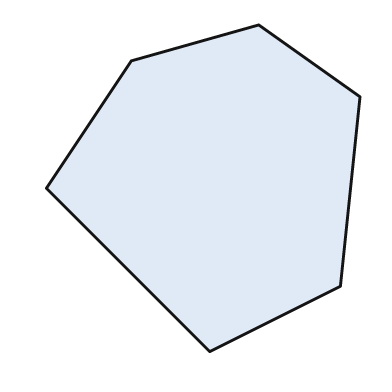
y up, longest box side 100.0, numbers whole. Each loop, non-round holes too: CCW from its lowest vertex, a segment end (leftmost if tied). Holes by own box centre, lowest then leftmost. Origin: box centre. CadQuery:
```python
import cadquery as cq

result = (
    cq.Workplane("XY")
    .moveTo(2.0, -50.0)
    .lineTo(42.0, -30.0)
    .lineTo(48.0, 28.0)
    .lineTo(17.0, 50.0)
    .lineTo(-22.0, 39.0)
    .lineTo(-48.0, 0.0)
    .close()
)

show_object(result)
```